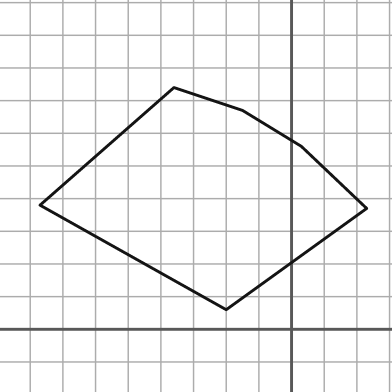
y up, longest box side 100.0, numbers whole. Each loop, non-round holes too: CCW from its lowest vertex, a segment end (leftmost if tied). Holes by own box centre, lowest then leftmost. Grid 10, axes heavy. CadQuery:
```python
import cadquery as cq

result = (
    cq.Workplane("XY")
    .moveTo(-20.0, 6.0)
    .lineTo(23.0, 37.0)
    .lineTo(3.0, 56.0)
    .lineTo(-15.0, 67.0)
    .lineTo(-36.0, 74.0)
    .lineTo(-77.0, 38.0)
    .close()
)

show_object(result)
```